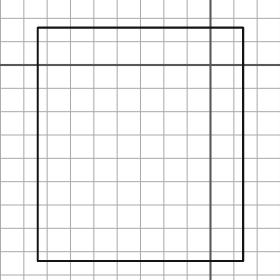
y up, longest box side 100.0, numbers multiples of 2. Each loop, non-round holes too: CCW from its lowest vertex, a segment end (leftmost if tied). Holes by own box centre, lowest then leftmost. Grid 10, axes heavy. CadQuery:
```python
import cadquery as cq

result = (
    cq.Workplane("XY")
    .moveTo(-74.0, -84.0)
    .lineTo(14.0, -84.0)
    .lineTo(14.0, 16.0)
    .lineTo(-74.0, 16.0)
    .close()
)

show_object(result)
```